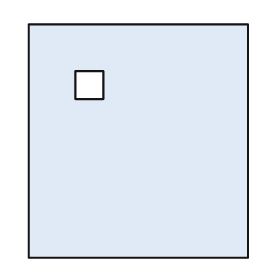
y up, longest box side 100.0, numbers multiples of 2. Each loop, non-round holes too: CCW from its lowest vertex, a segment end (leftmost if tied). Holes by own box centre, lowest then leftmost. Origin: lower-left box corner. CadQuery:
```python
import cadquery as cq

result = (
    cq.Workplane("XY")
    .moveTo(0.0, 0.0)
    .lineTo(94.0, 0.0)
    .lineTo(94.0, 100.0)
    .lineTo(0.0, 100.0)
    .close()
    .moveTo(20.0, 68.0)
    .lineTo(32.0, 68.0)
    .lineTo(32.0, 80.0)
    .lineTo(20.0, 80.0)
    .close()
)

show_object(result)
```